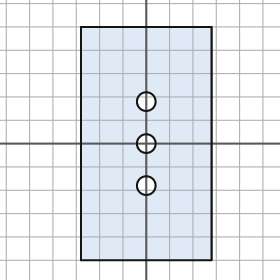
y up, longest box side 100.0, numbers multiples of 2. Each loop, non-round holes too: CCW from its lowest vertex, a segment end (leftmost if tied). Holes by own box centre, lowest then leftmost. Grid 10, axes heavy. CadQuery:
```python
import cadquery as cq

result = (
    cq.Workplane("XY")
    .moveTo(-28.0, -50.0)
    .lineTo(28.0, -50.0)
    .lineTo(28.0, 50.0)
    .lineTo(-28.0, 50.0)
    .close()
    .moveTo(0.0, -18.0)
    .circle(4.0)
    .moveTo(0.0, 0.0)
    .circle(4.0)
    .moveTo(0.0, 18.0)
    .circle(4.0)
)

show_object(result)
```